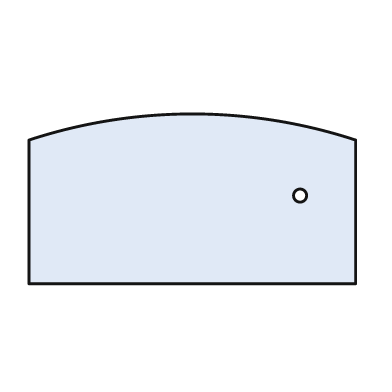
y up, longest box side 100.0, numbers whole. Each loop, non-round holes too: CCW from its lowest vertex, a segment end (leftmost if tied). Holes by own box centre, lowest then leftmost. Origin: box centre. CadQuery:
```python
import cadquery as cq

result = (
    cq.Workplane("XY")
    .moveTo(-50.0, -26.0)
    .lineTo(50.0, -26.0)
    .lineTo(50.0, 18.0)
    .threePointArc((0.0, 26.0), (-50.0, 18.0))
    .close()
    .moveTo(33.0, 1.0)
    .circle(2.0)
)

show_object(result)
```